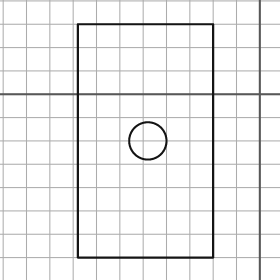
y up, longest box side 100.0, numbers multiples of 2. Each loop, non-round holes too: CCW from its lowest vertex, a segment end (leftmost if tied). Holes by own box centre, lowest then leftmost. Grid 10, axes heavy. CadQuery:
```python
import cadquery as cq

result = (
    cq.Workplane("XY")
    .moveTo(-78.0, -70.0)
    .lineTo(-20.0, -70.0)
    .lineTo(-20.0, 30.0)
    .lineTo(-78.0, 30.0)
    .close()
    .moveTo(-48.0, -20.0)
    .circle(8.0)
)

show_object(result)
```